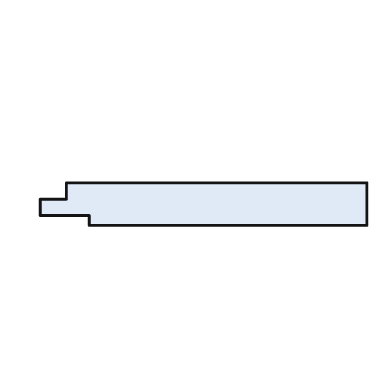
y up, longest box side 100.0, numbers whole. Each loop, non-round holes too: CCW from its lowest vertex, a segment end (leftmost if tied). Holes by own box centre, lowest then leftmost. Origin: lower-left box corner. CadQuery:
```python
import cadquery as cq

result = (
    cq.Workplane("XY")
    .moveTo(15.0, 0.0)
    .lineTo(100.0, 0.0)
    .lineTo(100.0, 13.0)
    .lineTo(8.0, 13.0)
    .lineTo(8.0, 8.0)
    .lineTo(0.0, 8.0)
    .lineTo(0.0, 3.0)
    .lineTo(15.0, 3.0)
    .close()
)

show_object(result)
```